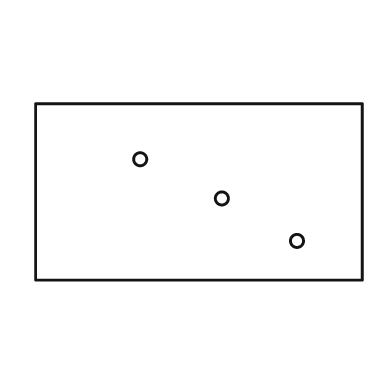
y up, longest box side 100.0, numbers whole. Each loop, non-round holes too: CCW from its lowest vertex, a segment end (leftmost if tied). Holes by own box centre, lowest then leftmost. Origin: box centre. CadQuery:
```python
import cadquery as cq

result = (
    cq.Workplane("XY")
    .moveTo(-50.0, -27.0)
    .lineTo(50.0, -27.0)
    .lineTo(50.0, 27.0)
    .lineTo(-50.0, 27.0)
    .close()
    .moveTo(30.0, -15.0)
    .circle(2.0)
    .moveTo(7.0, -2.0)
    .circle(2.0)
    .moveTo(-18.0, 10.0)
    .circle(2.0)
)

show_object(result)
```